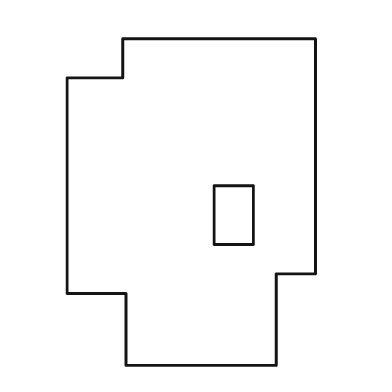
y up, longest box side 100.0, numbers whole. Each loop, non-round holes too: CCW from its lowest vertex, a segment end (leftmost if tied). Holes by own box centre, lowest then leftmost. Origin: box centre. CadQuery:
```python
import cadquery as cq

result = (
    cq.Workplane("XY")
    .moveTo(-20.0, -50.0)
    .lineTo(26.0, -50.0)
    .lineTo(26.0, -22.0)
    .lineTo(38.0, -22.0)
    .lineTo(38.0, 50.0)
    .lineTo(-21.0, 50.0)
    .lineTo(-21.0, 38.0)
    .lineTo(-38.0, 38.0)
    .lineTo(-38.0, -28.0)
    .lineTo(-20.0, -28.0)
    .close()
    .moveTo(7.0, -13.0)
    .lineTo(19.0, -13.0)
    .lineTo(19.0, 5.0)
    .lineTo(7.0, 5.0)
    .close()
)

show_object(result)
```